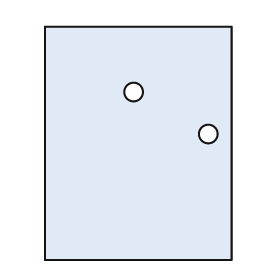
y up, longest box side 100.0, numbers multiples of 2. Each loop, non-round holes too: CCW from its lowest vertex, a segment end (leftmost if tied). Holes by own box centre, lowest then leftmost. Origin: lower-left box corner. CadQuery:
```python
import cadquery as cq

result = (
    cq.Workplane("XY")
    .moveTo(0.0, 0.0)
    .lineTo(80.0, 0.0)
    .lineTo(80.0, 100.0)
    .lineTo(0.0, 100.0)
    .close()
    .moveTo(70.0, 54.0)
    .circle(4.0)
    .moveTo(38.0, 72.0)
    .circle(4.0)
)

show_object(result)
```